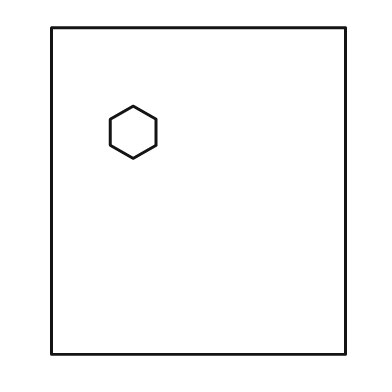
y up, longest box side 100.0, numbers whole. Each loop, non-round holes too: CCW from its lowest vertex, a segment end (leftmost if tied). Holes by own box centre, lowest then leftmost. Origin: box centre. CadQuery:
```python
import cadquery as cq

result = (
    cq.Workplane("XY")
    .moveTo(-45.0, -50.0)
    .lineTo(45.0, -50.0)
    .lineTo(45.0, 50.0)
    .lineTo(-45.0, 50.0)
    .close()
    .moveTo(-20.0, 10.0)
    .lineTo(-13.0, 14.0)
    .lineTo(-13.0, 22.0)
    .lineTo(-20.0, 26.0)
    .lineTo(-27.0, 22.0)
    .lineTo(-27.0, 14.0)
    .close()
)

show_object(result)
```